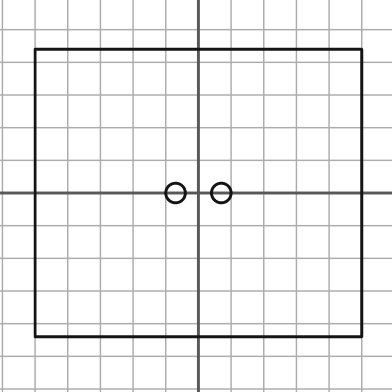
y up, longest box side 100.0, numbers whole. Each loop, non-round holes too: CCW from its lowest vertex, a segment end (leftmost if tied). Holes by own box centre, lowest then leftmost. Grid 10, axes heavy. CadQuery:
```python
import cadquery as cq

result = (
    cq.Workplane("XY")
    .moveTo(-50.0, -44.0)
    .lineTo(50.0, -44.0)
    .lineTo(50.0, 44.0)
    .lineTo(-50.0, 44.0)
    .close()
    .moveTo(-7.0, 0.0)
    .circle(3.0)
    .moveTo(7.0, 0.0)
    .circle(3.0)
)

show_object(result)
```